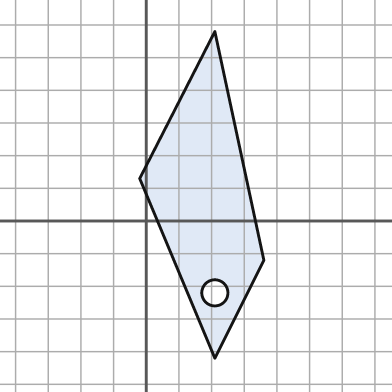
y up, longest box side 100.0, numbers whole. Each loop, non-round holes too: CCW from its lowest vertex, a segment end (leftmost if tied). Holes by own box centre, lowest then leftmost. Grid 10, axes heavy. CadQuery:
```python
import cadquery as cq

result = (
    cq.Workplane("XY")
    .moveTo(21.0, -42.0)
    .lineTo(36.0, -12.0)
    .lineTo(21.0, 58.0)
    .lineTo(-2.0, 13.0)
    .close()
    .moveTo(21.0, -22.0)
    .circle(4.0)
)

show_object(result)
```